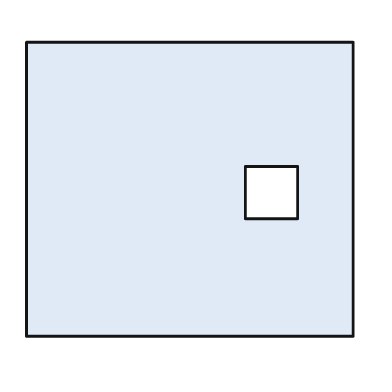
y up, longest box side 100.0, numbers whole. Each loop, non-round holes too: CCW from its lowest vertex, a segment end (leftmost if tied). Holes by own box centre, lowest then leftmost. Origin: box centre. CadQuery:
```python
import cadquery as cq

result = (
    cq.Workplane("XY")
    .moveTo(-50.0, -45.0)
    .lineTo(50.0, -45.0)
    .lineTo(50.0, 45.0)
    .lineTo(-50.0, 45.0)
    .close()
    .moveTo(17.0, -9.0)
    .lineTo(33.0, -9.0)
    .lineTo(33.0, 7.0)
    .lineTo(17.0, 7.0)
    .close()
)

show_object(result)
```